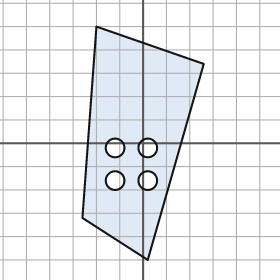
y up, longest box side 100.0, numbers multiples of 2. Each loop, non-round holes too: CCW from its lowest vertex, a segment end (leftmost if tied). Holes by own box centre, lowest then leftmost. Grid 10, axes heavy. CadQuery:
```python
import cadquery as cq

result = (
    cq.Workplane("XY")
    .moveTo(2.0, -50.0)
    .lineTo(26.0, 34.0)
    .lineTo(-20.0, 50.0)
    .lineTo(-26.0, -32.0)
    .close()
    .moveTo(-12.0, -16.0)
    .circle(4.0)
    .moveTo(2.0, -16.0)
    .circle(4.0)
    .moveTo(-12.0, -2.0)
    .circle(4.0)
    .moveTo(2.0, -2.0)
    .circle(4.0)
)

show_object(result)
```